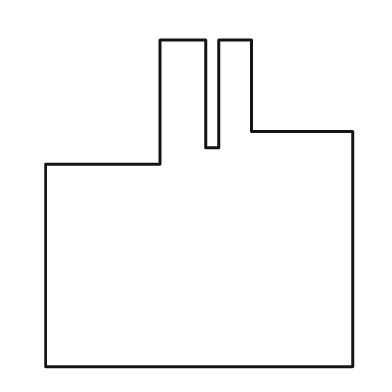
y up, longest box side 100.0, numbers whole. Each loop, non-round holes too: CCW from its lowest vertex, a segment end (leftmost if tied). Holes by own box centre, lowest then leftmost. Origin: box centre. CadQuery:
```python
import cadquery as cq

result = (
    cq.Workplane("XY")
    .moveTo(-47.0, -50.0)
    .lineTo(47.0, -50.0)
    .lineTo(47.0, 22.0)
    .lineTo(16.0, 22.0)
    .lineTo(16.0, 50.0)
    .lineTo(6.0, 50.0)
    .lineTo(6.0, 17.0)
    .lineTo(2.0, 17.0)
    .lineTo(2.0, 50.0)
    .lineTo(-12.0, 50.0)
    .lineTo(-12.0, 12.0)
    .lineTo(-47.0, 12.0)
    .close()
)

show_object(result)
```